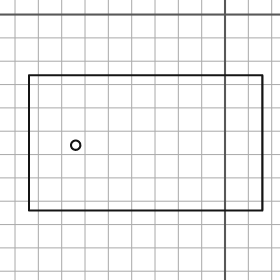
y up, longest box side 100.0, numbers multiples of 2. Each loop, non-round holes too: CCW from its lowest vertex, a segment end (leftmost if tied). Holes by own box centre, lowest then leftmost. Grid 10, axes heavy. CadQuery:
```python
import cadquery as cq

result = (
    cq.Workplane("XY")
    .moveTo(-84.0, -84.0)
    .lineTo(16.0, -84.0)
    .lineTo(16.0, -26.0)
    .lineTo(-84.0, -26.0)
    .close()
    .moveTo(-64.0, -56.0)
    .circle(2.0)
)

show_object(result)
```